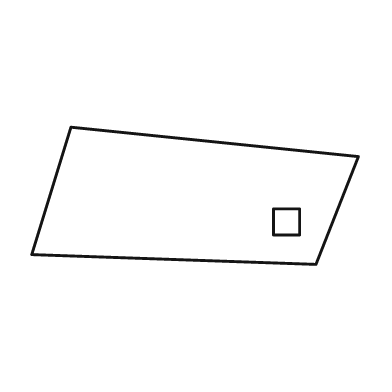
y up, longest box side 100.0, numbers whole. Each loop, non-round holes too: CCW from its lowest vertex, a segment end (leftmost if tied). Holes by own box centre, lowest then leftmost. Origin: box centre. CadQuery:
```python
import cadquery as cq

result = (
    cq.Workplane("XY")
    .moveTo(37.0, -21.0)
    .lineTo(50.0, 12.0)
    .lineTo(-38.0, 21.0)
    .lineTo(-50.0, -18.0)
    .close()
    .moveTo(24.0, -12.0)
    .lineTo(32.0, -12.0)
    .lineTo(32.0, -4.0)
    .lineTo(24.0, -4.0)
    .close()
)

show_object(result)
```